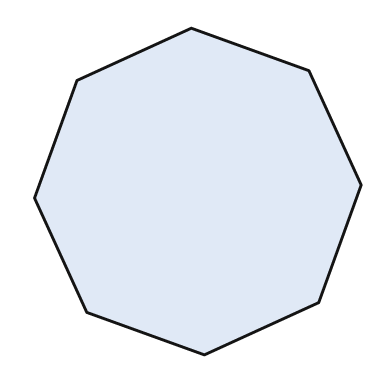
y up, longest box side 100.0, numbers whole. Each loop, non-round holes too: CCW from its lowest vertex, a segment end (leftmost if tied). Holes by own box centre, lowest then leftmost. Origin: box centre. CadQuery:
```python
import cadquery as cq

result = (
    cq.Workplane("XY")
    .moveTo(2.0, -50.0)
    .lineTo(37.0, -34.0)
    .lineTo(50.0, 2.0)
    .lineTo(34.0, 37.0)
    .lineTo(-2.0, 50.0)
    .lineTo(-37.0, 34.0)
    .lineTo(-50.0, -2.0)
    .lineTo(-34.0, -37.0)
    .close()
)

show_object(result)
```